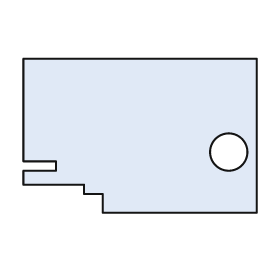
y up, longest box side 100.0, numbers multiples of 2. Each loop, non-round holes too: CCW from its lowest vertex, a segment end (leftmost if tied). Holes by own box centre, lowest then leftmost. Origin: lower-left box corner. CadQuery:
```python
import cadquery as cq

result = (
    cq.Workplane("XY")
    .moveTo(34.0, 0.0)
    .lineTo(100.0, 0.0)
    .lineTo(100.0, 66.0)
    .lineTo(0.0, 66.0)
    .lineTo(0.0, 22.0)
    .lineTo(14.0, 22.0)
    .lineTo(14.0, 18.0)
    .lineTo(0.0, 18.0)
    .lineTo(0.0, 12.0)
    .lineTo(26.0, 12.0)
    .lineTo(26.0, 8.0)
    .lineTo(34.0, 8.0)
    .close()
    .moveTo(88.0, 26.0)
    .circle(8.0)
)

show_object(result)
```